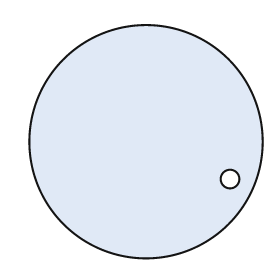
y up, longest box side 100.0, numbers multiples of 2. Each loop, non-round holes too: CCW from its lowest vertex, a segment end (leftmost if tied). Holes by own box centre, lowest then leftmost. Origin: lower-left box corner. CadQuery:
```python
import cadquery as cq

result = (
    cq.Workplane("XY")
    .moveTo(50.0, 50.0)
    .circle(50.0)
    .moveTo(86.0, 34.0)
    .circle(4.0)
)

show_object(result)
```